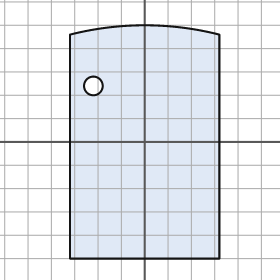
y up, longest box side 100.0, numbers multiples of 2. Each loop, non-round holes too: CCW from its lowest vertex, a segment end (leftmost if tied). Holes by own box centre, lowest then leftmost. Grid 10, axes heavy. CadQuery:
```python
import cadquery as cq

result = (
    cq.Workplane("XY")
    .moveTo(-32.0, -50.0)
    .lineTo(32.0, -50.0)
    .lineTo(32.0, 46.0)
    .threePointArc((0.0, 50.0), (-32.0, 46.0))
    .close()
    .moveTo(-22.0, 24.0)
    .circle(4.0)
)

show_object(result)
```